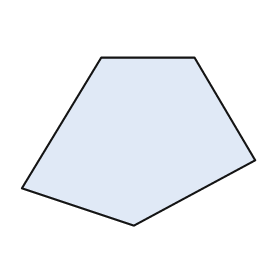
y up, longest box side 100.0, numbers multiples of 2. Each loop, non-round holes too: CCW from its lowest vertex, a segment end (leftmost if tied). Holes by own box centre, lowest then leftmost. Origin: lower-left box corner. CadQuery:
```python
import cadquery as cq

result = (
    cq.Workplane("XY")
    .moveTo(48.0, 0.0)
    .lineTo(100.0, 28.0)
    .lineTo(74.0, 72.0)
    .lineTo(34.0, 72.0)
    .lineTo(0.0, 16.0)
    .close()
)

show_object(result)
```